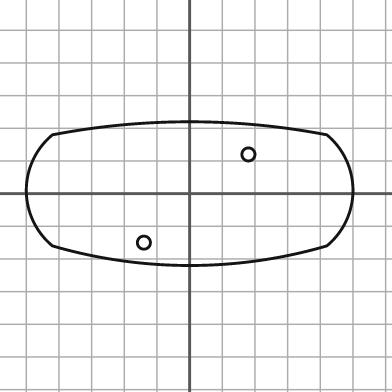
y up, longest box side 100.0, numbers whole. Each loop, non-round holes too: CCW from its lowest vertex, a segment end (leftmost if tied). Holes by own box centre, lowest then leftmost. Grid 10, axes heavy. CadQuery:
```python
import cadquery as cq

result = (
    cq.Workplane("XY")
    .moveTo(-42.0, -16.0)
    .threePointArc((0.0, -22.0), (42.0, -16.0))
    .threePointArc((50.0, 1.0), (42.0, 18.0))
    .threePointArc((0.0, 22.0), (-42.0, 18.0))
    .threePointArc((-50.0, 1.0), (-42.0, -16.0))
    .close()
    .moveTo(-14.0, -15.0)
    .circle(2.0)
    .moveTo(18.0, 12.0)
    .circle(2.0)
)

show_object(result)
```